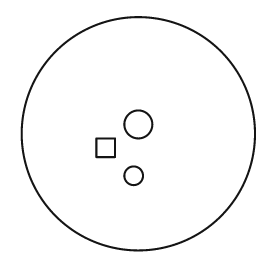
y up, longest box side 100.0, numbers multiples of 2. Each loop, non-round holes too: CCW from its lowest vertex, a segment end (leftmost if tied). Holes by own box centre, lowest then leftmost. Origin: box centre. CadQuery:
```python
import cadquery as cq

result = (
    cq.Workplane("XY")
    .moveTo(0.0, 0.0)
    .circle(50.0)
    .moveTo(-2.0, -18.0)
    .circle(4.0)
    .moveTo(-18.0, -10.0)
    .lineTo(-10.0, -10.0)
    .lineTo(-10.0, -2.0)
    .lineTo(-18.0, -2.0)
    .close()
    .moveTo(0.0, 4.0)
    .circle(6.0)
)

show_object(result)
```